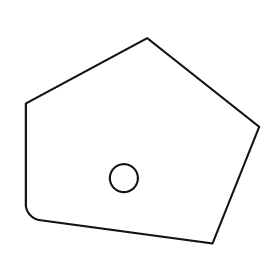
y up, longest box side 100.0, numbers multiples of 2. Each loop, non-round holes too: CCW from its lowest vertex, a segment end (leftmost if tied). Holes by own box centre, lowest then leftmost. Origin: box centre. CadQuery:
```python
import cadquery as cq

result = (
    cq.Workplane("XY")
    .moveTo(30.0, -44.0)
    .lineTo(50.0, 6.0)
    .lineTo(2.0, 44.0)
    .lineTo(-50.0, 16.0)
    .lineTo(-50.0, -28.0)
    .threePointArc((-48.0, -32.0), (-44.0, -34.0))
    .close()
    .moveTo(-8.0, -16.0)
    .circle(6.0)
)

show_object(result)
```